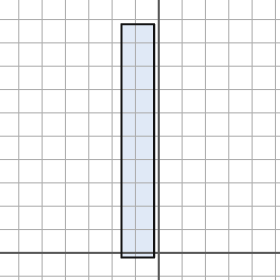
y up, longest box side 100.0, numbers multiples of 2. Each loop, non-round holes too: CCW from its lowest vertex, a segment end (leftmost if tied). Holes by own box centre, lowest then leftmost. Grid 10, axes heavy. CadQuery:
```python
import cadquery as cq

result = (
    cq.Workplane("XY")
    .moveTo(-16.0, -2.0)
    .lineTo(-2.0, -2.0)
    .lineTo(-2.0, 98.0)
    .lineTo(-16.0, 98.0)
    .close()
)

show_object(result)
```